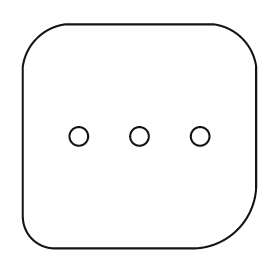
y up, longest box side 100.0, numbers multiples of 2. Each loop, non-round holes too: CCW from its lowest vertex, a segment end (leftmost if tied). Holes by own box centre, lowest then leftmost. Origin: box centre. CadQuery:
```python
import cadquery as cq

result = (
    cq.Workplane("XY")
    .moveTo(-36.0, -48.0)
    .lineTo(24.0, -48.0)
    .threePointArc((42.0, -40.0), (50.0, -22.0))
    .lineTo(50.0, 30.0)
    .threePointArc((44.0, 42.0), (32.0, 48.0))
    .lineTo(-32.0, 48.0)
    .threePointArc((-44.0, 42.0), (-50.0, 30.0))
    .lineTo(-50.0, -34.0)
    .threePointArc((-46.0, -44.0), (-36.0, -48.0))
    .close()
    .moveTo(-26.0, 0.0)
    .circle(4.0)
    .moveTo(0.0, 0.0)
    .circle(4.0)
    .moveTo(26.0, 0.0)
    .circle(4.0)
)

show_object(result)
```